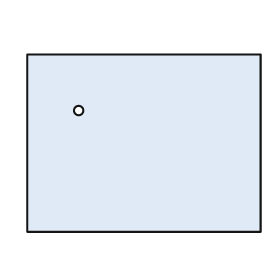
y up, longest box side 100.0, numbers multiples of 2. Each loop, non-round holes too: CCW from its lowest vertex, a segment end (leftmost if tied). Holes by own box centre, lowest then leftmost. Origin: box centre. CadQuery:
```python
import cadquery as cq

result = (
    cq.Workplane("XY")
    .moveTo(-50.0, -38.0)
    .lineTo(50.0, -38.0)
    .lineTo(50.0, 38.0)
    .lineTo(-50.0, 38.0)
    .close()
    .moveTo(-28.0, 14.0)
    .circle(2.0)
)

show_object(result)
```